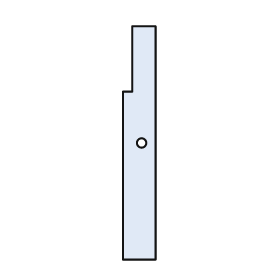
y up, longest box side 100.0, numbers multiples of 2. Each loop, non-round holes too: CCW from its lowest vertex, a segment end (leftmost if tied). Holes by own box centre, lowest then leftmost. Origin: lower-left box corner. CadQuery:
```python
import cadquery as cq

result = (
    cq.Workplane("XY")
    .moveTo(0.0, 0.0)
    .lineTo(14.0, 0.0)
    .lineTo(14.0, 100.0)
    .lineTo(4.0, 100.0)
    .lineTo(4.0, 72.0)
    .lineTo(0.0, 72.0)
    .close()
    .moveTo(8.0, 50.0)
    .circle(2.0)
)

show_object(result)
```